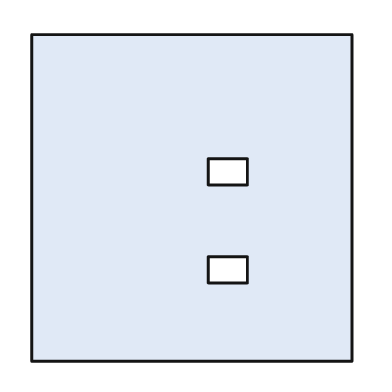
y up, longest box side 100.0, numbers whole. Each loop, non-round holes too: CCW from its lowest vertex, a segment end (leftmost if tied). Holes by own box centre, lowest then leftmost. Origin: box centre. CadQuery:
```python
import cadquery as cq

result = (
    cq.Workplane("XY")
    .moveTo(-49.0, -50.0)
    .lineTo(49.0, -50.0)
    .lineTo(49.0, 50.0)
    .lineTo(-49.0, 50.0)
    .close()
    .moveTo(5.0, -26.0)
    .lineTo(17.0, -26.0)
    .lineTo(17.0, -18.0)
    .lineTo(5.0, -18.0)
    .close()
    .moveTo(5.0, 4.0)
    .lineTo(17.0, 4.0)
    .lineTo(17.0, 12.0)
    .lineTo(5.0, 12.0)
    .close()
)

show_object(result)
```